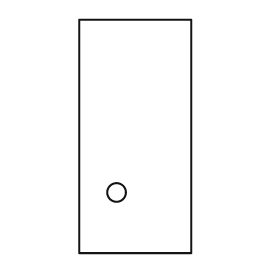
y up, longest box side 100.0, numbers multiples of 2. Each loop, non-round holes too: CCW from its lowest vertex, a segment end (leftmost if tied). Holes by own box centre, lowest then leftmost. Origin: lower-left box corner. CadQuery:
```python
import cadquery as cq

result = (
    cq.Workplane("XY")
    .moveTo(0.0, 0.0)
    .lineTo(48.0, 0.0)
    .lineTo(48.0, 100.0)
    .lineTo(0.0, 100.0)
    .close()
    .moveTo(16.0, 26.0)
    .circle(4.0)
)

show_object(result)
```